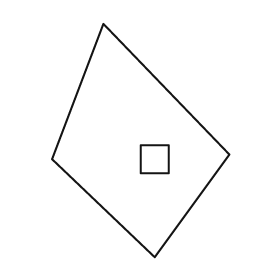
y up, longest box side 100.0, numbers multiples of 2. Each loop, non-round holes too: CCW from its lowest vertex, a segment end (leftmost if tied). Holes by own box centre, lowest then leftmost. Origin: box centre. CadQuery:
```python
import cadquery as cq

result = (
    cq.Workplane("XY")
    .moveTo(6.0, -50.0)
    .lineTo(38.0, -6.0)
    .lineTo(-16.0, 50.0)
    .lineTo(-38.0, -8.0)
    .close()
    .moveTo(0.0, -14.0)
    .lineTo(12.0, -14.0)
    .lineTo(12.0, -2.0)
    .lineTo(0.0, -2.0)
    .close()
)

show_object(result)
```